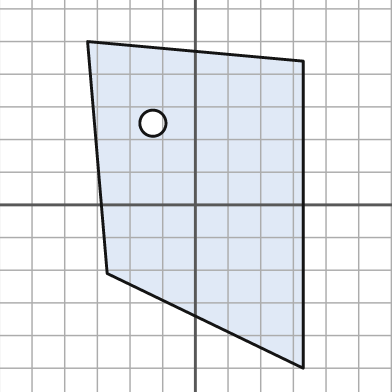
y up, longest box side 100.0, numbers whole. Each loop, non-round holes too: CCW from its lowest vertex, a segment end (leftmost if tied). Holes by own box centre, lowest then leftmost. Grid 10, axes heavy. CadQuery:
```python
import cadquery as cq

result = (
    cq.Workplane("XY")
    .moveTo(33.0, -50.0)
    .lineTo(33.0, 44.0)
    .lineTo(-33.0, 50.0)
    .lineTo(-27.0, -21.0)
    .close()
    .moveTo(-13.0, 25.0)
    .circle(4.0)
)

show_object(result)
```